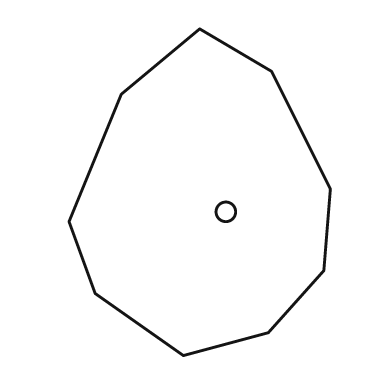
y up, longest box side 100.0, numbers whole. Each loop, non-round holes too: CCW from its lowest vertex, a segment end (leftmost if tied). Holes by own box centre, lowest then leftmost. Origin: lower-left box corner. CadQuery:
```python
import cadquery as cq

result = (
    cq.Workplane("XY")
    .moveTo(35.0, 0.0)
    .lineTo(61.0, 7.0)
    .lineTo(78.0, 26.0)
    .lineTo(80.0, 51.0)
    .lineTo(62.0, 87.0)
    .lineTo(40.0, 100.0)
    .lineTo(16.0, 80.0)
    .lineTo(0.0, 41.0)
    .lineTo(8.0, 19.0)
    .close()
    .moveTo(48.0, 44.0)
    .circle(3.0)
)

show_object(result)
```